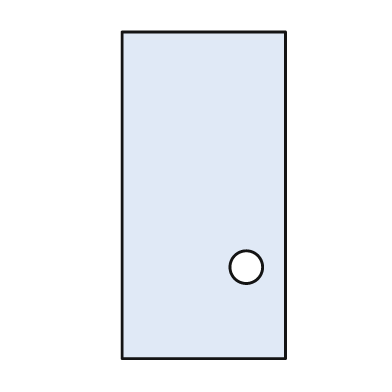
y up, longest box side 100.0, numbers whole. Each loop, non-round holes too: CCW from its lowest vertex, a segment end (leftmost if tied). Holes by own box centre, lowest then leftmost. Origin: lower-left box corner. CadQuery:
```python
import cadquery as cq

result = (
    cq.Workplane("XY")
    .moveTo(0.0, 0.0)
    .lineTo(50.0, 0.0)
    .lineTo(50.0, 100.0)
    .lineTo(0.0, 100.0)
    .close()
    .moveTo(38.0, 28.0)
    .circle(5.0)
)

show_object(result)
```